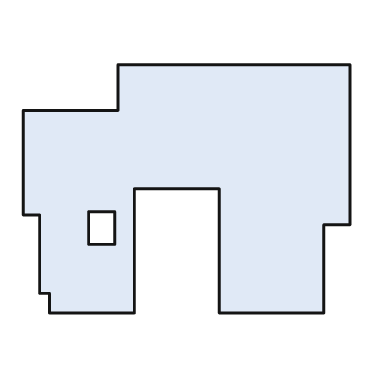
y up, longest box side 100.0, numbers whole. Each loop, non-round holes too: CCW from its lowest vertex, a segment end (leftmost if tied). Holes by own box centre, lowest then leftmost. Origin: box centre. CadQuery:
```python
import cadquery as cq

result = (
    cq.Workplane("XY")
    .moveTo(-42.0, -38.0)
    .lineTo(-16.0, -38.0)
    .lineTo(-16.0, 0.0)
    .lineTo(10.0, 0.0)
    .lineTo(10.0, -38.0)
    .lineTo(42.0, -38.0)
    .lineTo(42.0, -11.0)
    .lineTo(50.0, -11.0)
    .lineTo(50.0, 38.0)
    .lineTo(-21.0, 38.0)
    .lineTo(-21.0, 24.0)
    .lineTo(-50.0, 24.0)
    .lineTo(-50.0, -8.0)
    .lineTo(-45.0, -8.0)
    .lineTo(-45.0, -32.0)
    .lineTo(-42.0, -32.0)
    .close()
    .moveTo(-30.0, -17.0)
    .lineTo(-22.0, -17.0)
    .lineTo(-22.0, -7.0)
    .lineTo(-30.0, -7.0)
    .close()
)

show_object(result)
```